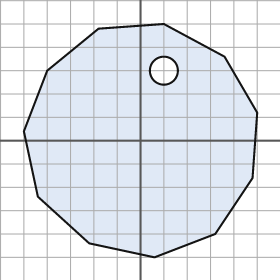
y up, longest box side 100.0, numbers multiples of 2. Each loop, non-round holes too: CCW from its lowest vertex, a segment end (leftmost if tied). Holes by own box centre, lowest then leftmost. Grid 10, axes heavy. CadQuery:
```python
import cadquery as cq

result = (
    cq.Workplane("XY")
    .moveTo(6.0, -50.0)
    .lineTo(32.0, -40.0)
    .lineTo(48.0, -16.0)
    .lineTo(50.0, 12.0)
    .lineTo(36.0, 36.0)
    .lineTo(10.0, 50.0)
    .lineTo(-18.0, 48.0)
    .lineTo(-40.0, 30.0)
    .lineTo(-50.0, 4.0)
    .lineTo(-44.0, -24.0)
    .lineTo(-22.0, -44.0)
    .close()
    .moveTo(10.0, 30.0)
    .circle(6.0)
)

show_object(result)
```